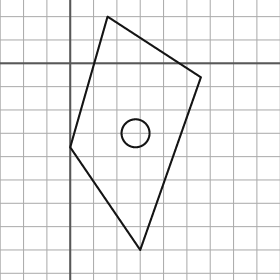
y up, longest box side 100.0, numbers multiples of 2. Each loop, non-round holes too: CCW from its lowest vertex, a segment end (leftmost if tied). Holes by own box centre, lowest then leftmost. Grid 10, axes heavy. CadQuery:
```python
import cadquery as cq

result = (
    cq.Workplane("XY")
    .moveTo(30.0, -80.0)
    .lineTo(56.0, -6.0)
    .lineTo(16.0, 20.0)
    .lineTo(0.0, -36.0)
    .close()
    .moveTo(28.0, -30.0)
    .circle(6.0)
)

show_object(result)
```